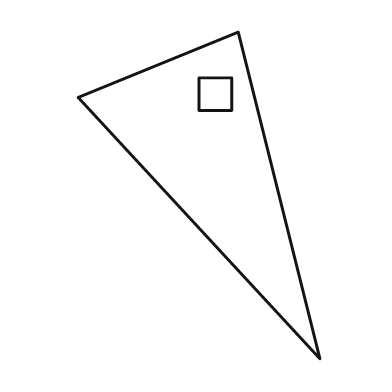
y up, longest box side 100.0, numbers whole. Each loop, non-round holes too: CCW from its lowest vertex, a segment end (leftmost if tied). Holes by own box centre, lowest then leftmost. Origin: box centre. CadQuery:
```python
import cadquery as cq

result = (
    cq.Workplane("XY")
    .moveTo(37.0, -50.0)
    .lineTo(12.0, 50.0)
    .lineTo(-37.0, 30.0)
    .close()
    .moveTo(0.0, 26.0)
    .lineTo(10.0, 26.0)
    .lineTo(10.0, 36.0)
    .lineTo(0.0, 36.0)
    .close()
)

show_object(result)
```